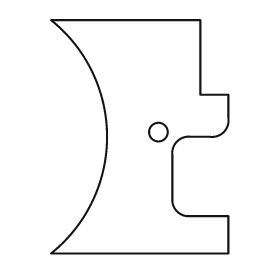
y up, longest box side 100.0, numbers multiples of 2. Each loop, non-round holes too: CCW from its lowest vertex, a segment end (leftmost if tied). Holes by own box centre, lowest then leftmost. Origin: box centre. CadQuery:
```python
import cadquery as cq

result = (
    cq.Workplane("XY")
    .moveTo(-38.0, -50.0)
    .lineTo(38.0, -50.0)
    .lineTo(38.0, -34.0)
    .lineTo(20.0, -34.0)
    .threePointArc((16.0, -32.0), (14.0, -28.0))
    .lineTo(14.0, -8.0)
    .threePointArc((16.0, -2.0), (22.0, 0.0))
    .lineTo(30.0, 0.0)
    .threePointArc((36.0, 2.0), (38.0, 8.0))
    .lineTo(38.0, 18.0)
    .lineTo(26.0, 18.0)
    .lineTo(26.0, 50.0)
    .lineTo(-38.0, 50.0)
    .threePointArc((-14.0, 0.0), (-38.0, -50.0))
    .close()
    .moveTo(8.0, 2.0)
    .circle(4.0)
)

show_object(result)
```